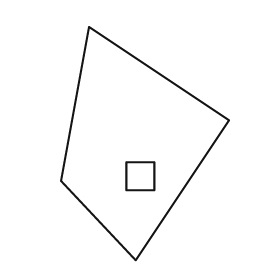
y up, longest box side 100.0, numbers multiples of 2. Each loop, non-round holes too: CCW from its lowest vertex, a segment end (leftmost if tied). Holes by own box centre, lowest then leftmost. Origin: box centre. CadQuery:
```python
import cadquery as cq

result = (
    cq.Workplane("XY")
    .moveTo(-4.0, -50.0)
    .lineTo(36.0, 10.0)
    .lineTo(-24.0, 50.0)
    .lineTo(-36.0, -16.0)
    .close()
    .moveTo(-8.0, -20.0)
    .lineTo(4.0, -20.0)
    .lineTo(4.0, -8.0)
    .lineTo(-8.0, -8.0)
    .close()
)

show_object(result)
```